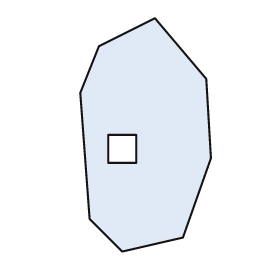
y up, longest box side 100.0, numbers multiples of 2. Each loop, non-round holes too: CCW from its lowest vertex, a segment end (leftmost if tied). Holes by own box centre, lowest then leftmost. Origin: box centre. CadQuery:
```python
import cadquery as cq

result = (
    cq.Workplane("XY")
    .moveTo(-10.0, -50.0)
    .lineTo(16.0, -44.0)
    .lineTo(28.0, -10.0)
    .lineTo(26.0, 24.0)
    .lineTo(4.0, 50.0)
    .lineTo(-20.0, 38.0)
    .lineTo(-28.0, 18.0)
    .lineTo(-24.0, -36.0)
    .close()
    .moveTo(-16.0, -12.0)
    .lineTo(-4.0, -12.0)
    .lineTo(-4.0, 0.0)
    .lineTo(-16.0, 0.0)
    .close()
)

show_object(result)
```